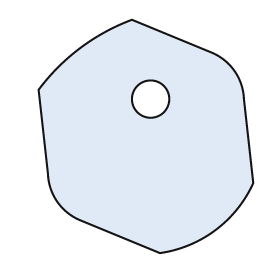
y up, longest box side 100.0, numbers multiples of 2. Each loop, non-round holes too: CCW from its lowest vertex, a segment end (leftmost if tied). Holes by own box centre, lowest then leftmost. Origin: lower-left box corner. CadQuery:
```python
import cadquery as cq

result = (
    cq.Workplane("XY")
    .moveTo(52.0, 0.0)
    .threePointArc((76.0, 10.0), (92.0, 30.0))
    .lineTo(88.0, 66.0)
    .threePointArc((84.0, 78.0), (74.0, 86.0))
    .lineTo(40.0, 100.0)
    .threePointArc((18.0, 88.0), (0.0, 70.0))
    .lineTo(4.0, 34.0)
    .threePointArc((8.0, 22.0), (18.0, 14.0))
    .close()
    .moveTo(48.0, 66.0)
    .circle(8.0)
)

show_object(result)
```